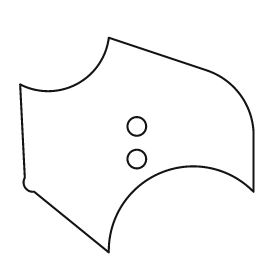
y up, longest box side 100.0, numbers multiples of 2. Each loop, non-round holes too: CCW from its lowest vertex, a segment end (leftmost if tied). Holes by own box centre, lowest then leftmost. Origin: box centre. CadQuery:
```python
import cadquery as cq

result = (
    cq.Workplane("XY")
    .moveTo(-12.0, -46.0)
    .threePointArc((10.0, -12.0), (50.0, -20.0))
    .lineTo(50.0, 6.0)
    .threePointArc((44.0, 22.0), (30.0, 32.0))
    .lineTo(-12.0, 46.0)
    .threePointArc((-26.0, 26.0), (-50.0, 26.0))
    .lineTo(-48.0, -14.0)
    .threePointArc((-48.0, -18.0), (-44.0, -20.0))
    .close()
    .moveTo(0.0, -6.0)
    .circle(4.0)
    .moveTo(0.0, 8.0)
    .circle(4.0)
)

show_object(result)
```